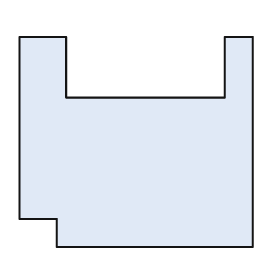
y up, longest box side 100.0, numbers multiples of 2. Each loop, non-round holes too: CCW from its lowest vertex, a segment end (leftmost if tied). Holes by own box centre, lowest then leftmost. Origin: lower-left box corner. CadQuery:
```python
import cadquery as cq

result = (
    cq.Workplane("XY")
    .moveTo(16.0, 0.0)
    .lineTo(100.0, 0.0)
    .lineTo(100.0, 90.0)
    .lineTo(88.0, 90.0)
    .lineTo(88.0, 64.0)
    .lineTo(20.0, 64.0)
    .lineTo(20.0, 90.0)
    .lineTo(0.0, 90.0)
    .lineTo(0.0, 12.0)
    .lineTo(16.0, 12.0)
    .close()
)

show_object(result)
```